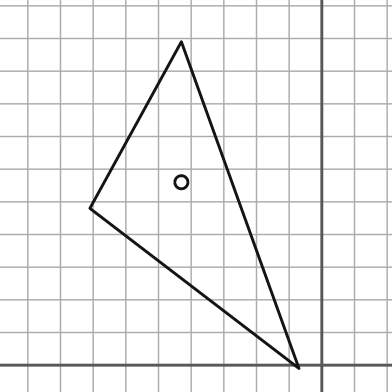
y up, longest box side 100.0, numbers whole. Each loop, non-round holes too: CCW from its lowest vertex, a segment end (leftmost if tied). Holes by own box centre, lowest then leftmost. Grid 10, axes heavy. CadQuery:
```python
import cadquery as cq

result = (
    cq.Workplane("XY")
    .moveTo(-7.0, -1.0)
    .lineTo(-43.0, 99.0)
    .lineTo(-71.0, 48.0)
    .close()
    .moveTo(-43.0, 56.0)
    .circle(2.0)
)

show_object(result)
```